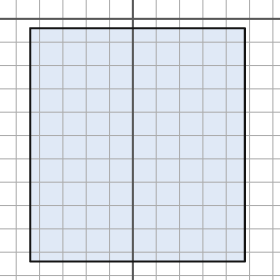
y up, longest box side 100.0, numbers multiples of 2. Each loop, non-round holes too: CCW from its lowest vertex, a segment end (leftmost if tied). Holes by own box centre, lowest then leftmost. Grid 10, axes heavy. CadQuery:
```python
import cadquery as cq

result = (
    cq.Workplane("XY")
    .moveTo(-44.0, -104.0)
    .lineTo(48.0, -104.0)
    .lineTo(48.0, -4.0)
    .lineTo(-44.0, -4.0)
    .close()
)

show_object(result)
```